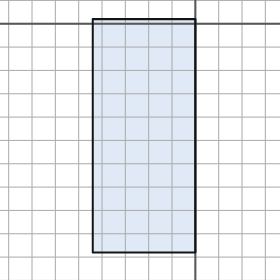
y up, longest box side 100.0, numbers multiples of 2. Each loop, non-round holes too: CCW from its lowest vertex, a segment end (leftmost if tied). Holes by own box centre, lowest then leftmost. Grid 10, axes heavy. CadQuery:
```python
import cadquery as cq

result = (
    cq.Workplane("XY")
    .moveTo(-44.0, -98.0)
    .lineTo(0.0, -98.0)
    .lineTo(0.0, 2.0)
    .lineTo(-44.0, 2.0)
    .close()
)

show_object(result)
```